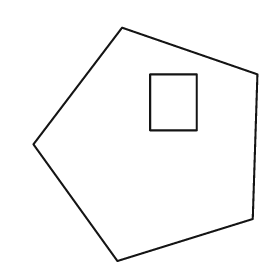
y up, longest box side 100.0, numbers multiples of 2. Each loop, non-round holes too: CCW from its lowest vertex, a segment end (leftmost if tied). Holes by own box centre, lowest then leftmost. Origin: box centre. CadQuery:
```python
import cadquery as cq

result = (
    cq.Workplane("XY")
    .moveTo(-12.0, -50.0)
    .lineTo(46.0, -32.0)
    .lineTo(48.0, 30.0)
    .lineTo(-10.0, 50.0)
    .lineTo(-48.0, 0.0)
    .close()
    .moveTo(2.0, 6.0)
    .lineTo(22.0, 6.0)
    .lineTo(22.0, 30.0)
    .lineTo(2.0, 30.0)
    .close()
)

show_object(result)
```